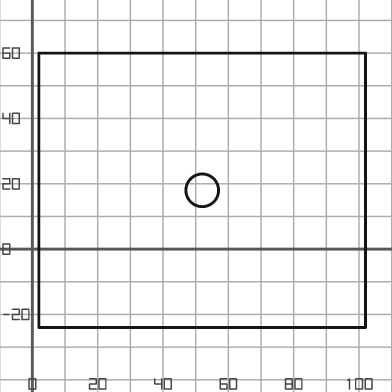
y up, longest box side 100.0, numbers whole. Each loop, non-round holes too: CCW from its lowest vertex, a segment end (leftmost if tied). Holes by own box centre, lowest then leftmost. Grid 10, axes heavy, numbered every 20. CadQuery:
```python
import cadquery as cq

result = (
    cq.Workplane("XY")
    .moveTo(2.0, -24.0)
    .lineTo(102.0, -24.0)
    .lineTo(102.0, 60.0)
    .lineTo(2.0, 60.0)
    .close()
    .moveTo(52.0, 18.0)
    .circle(5.0)
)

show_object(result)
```